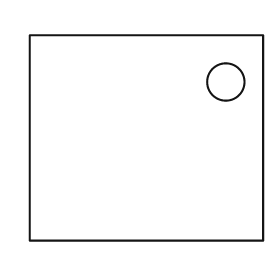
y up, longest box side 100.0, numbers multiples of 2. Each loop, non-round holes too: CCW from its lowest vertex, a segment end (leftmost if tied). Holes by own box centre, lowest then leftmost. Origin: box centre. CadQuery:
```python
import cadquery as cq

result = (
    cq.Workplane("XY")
    .moveTo(-50.0, -44.0)
    .lineTo(50.0, -44.0)
    .lineTo(50.0, 44.0)
    .lineTo(-50.0, 44.0)
    .close()
    .moveTo(34.0, 24.0)
    .circle(8.0)
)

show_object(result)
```